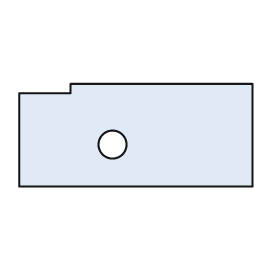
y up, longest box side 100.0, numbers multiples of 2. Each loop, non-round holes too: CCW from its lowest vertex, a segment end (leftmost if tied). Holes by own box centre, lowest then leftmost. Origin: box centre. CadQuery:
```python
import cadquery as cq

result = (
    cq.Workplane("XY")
    .moveTo(-50.0, -22.0)
    .lineTo(50.0, -22.0)
    .lineTo(50.0, 22.0)
    .lineTo(-28.0, 22.0)
    .lineTo(-28.0, 18.0)
    .lineTo(-50.0, 18.0)
    .close()
    .moveTo(-10.0, -4.0)
    .circle(6.0)
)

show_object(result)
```